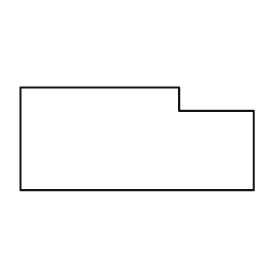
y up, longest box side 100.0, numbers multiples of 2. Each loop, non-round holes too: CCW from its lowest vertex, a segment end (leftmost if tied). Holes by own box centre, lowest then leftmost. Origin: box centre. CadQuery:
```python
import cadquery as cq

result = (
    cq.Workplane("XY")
    .moveTo(-50.0, -22.0)
    .lineTo(50.0, -22.0)
    .lineTo(50.0, 12.0)
    .lineTo(18.0, 12.0)
    .lineTo(18.0, 22.0)
    .lineTo(-50.0, 22.0)
    .close()
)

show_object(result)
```